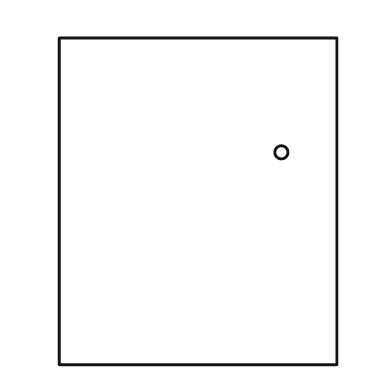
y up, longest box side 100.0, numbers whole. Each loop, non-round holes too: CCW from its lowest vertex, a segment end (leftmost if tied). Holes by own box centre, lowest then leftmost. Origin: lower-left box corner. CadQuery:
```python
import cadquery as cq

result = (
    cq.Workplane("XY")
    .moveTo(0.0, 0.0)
    .lineTo(85.0, 0.0)
    .lineTo(85.0, 100.0)
    .lineTo(0.0, 100.0)
    .close()
    .moveTo(68.0, 65.0)
    .circle(2.0)
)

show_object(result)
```